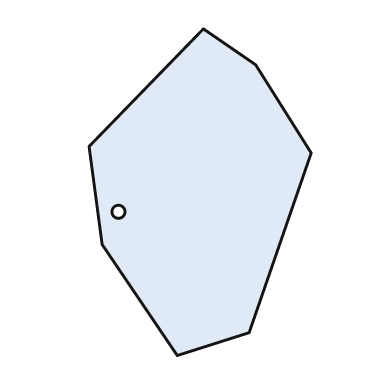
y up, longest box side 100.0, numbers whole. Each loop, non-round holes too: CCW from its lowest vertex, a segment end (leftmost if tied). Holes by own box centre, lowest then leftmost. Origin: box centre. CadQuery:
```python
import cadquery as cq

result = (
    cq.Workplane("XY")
    .moveTo(-7.0, -50.0)
    .lineTo(15.0, -43.0)
    .lineTo(34.0, 12.0)
    .lineTo(17.0, 39.0)
    .lineTo(1.0, 50.0)
    .lineTo(-34.0, 14.0)
    .lineTo(-30.0, -16.0)
    .close()
    .moveTo(-25.0, -6.0)
    .circle(2.0)
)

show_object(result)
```